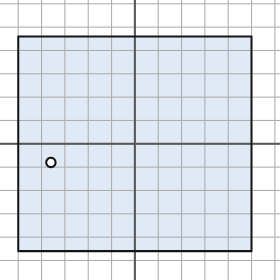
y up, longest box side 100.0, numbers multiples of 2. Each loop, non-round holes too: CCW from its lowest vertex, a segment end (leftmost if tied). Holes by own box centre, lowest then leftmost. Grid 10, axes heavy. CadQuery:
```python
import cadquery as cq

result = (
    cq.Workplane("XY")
    .moveTo(-50.0, -46.0)
    .lineTo(50.0, -46.0)
    .lineTo(50.0, 46.0)
    .lineTo(-50.0, 46.0)
    .close()
    .moveTo(-36.0, -8.0)
    .circle(2.0)
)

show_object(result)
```